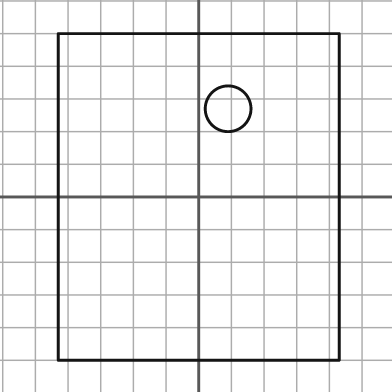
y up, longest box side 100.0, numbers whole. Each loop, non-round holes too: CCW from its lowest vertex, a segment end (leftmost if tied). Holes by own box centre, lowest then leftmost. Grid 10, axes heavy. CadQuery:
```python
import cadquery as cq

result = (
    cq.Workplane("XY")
    .moveTo(-43.0, -50.0)
    .lineTo(43.0, -50.0)
    .lineTo(43.0, 50.0)
    .lineTo(-43.0, 50.0)
    .close()
    .moveTo(9.0, 27.0)
    .circle(7.0)
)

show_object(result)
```